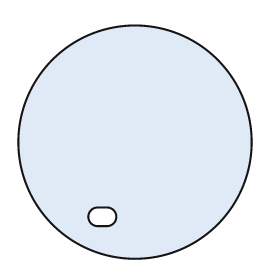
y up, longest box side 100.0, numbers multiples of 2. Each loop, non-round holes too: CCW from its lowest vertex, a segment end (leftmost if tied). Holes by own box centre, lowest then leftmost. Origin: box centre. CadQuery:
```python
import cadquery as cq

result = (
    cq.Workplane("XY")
    .moveTo(0.0, 0.0)
    .circle(50.0)
    .moveTo(-16.0, -36.0)
    .lineTo(-12.0, -36.0)
    .threePointArc((-8.0, -32.0), (-12.0, -28.0))
    .lineTo(-16.0, -28.0)
    .threePointArc((-20.0, -32.0), (-16.0, -36.0))
    .close()
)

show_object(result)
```